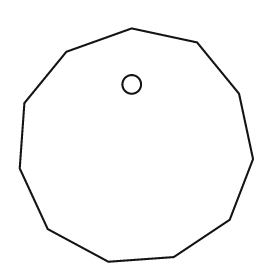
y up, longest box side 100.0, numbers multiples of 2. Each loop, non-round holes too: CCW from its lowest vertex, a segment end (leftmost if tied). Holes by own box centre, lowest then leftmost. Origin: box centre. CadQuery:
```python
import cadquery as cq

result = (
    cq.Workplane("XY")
    .moveTo(-12.0, -50.0)
    .lineTo(16.0, -48.0)
    .lineTo(40.0, -32.0)
    .lineTo(50.0, -6.0)
    .lineTo(44.0, 22.0)
    .lineTo(26.0, 44.0)
    .lineTo(-2.0, 50.0)
    .lineTo(-30.0, 40.0)
    .lineTo(-48.0, 18.0)
    .lineTo(-50.0, -10.0)
    .lineTo(-38.0, -36.0)
    .close()
    .moveTo(-2.0, 26.0)
    .circle(4.0)
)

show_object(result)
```